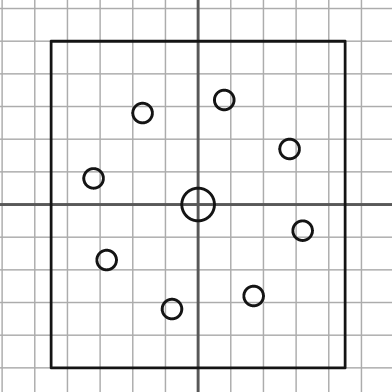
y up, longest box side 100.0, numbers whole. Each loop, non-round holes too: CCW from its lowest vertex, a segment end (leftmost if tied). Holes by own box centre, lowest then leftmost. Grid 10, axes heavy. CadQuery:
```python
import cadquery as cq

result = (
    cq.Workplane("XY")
    .moveTo(-45.0, -50.0)
    .lineTo(45.0, -50.0)
    .lineTo(45.0, 50.0)
    .lineTo(-45.0, 50.0)
    .close()
    .moveTo(-8.0, -32.0)
    .circle(3.0)
    .moveTo(17.0, -28.0)
    .circle(3.0)
    .moveTo(-28.0, -17.0)
    .circle(3.0)
    .moveTo(32.0, -8.0)
    .circle(3.0)
    .moveTo(0.0, 0.0)
    .circle(5.0)
    .moveTo(-32.0, 8.0)
    .circle(3.0)
    .moveTo(28.0, 17.0)
    .circle(3.0)
    .moveTo(-17.0, 28.0)
    .circle(3.0)
    .moveTo(8.0, 32.0)
    .circle(3.0)
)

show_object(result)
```